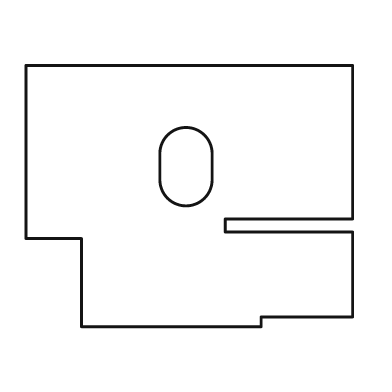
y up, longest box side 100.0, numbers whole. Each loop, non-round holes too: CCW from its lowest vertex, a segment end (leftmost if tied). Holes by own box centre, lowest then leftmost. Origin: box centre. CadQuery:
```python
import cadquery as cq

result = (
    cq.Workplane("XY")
    .moveTo(-33.0, -40.0)
    .lineTo(22.0, -40.0)
    .lineTo(22.0, -37.0)
    .lineTo(50.0, -37.0)
    .lineTo(50.0, -11.0)
    .lineTo(11.0, -11.0)
    .lineTo(11.0, -7.0)
    .lineTo(50.0, -7.0)
    .lineTo(50.0, 40.0)
    .lineTo(-50.0, 40.0)
    .lineTo(-50.0, -13.0)
    .lineTo(-33.0, -13.0)
    .close()
    .moveTo(-9.0, 5.0)
    .threePointArc((-1.0, -3.0), (7.0, 5.0))
    .lineTo(7.0, 13.0)
    .threePointArc((-1.0, 21.0), (-9.0, 13.0))
    .close()
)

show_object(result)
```